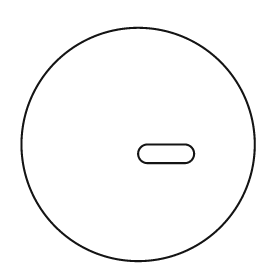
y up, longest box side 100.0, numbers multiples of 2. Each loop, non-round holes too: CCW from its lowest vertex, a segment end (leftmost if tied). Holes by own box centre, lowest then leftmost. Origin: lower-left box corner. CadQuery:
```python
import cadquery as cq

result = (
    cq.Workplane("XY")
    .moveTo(50.0, 50.0)
    .circle(50.0)
    .moveTo(54.0, 42.0)
    .lineTo(70.0, 42.0)
    .threePointArc((74.0, 46.0), (70.0, 50.0))
    .lineTo(54.0, 50.0)
    .threePointArc((50.0, 46.0), (54.0, 42.0))
    .close()
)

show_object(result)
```